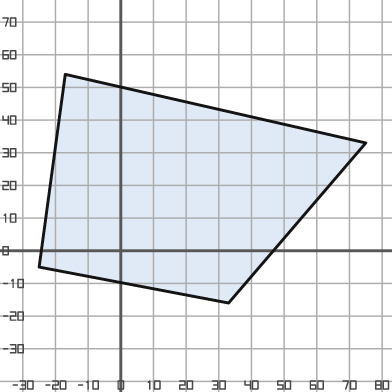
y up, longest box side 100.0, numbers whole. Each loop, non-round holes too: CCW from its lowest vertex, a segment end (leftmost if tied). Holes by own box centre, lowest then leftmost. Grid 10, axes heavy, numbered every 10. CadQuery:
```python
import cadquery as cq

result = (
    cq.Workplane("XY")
    .moveTo(33.0, -16.0)
    .lineTo(75.0, 33.0)
    .lineTo(-17.0, 54.0)
    .lineTo(-25.0, -5.0)
    .close()
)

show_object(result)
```